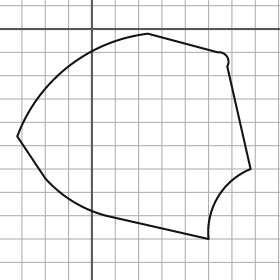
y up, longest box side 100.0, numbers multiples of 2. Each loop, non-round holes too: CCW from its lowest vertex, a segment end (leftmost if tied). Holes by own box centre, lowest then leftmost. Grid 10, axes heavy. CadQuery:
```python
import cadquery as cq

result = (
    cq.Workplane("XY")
    .moveTo(50.0, -90.0)
    .threePointArc((54.0, -72.0), (68.0, -60.0))
    .lineTo(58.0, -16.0)
    .threePointArc((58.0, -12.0), (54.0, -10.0))
    .lineTo(24.0, -2.0)
    .threePointArc((-10.0, -16.0), (-32.0, -46.0))
    .lineTo(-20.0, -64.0)
    .threePointArc((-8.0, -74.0), (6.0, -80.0))
    .close()
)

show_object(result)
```